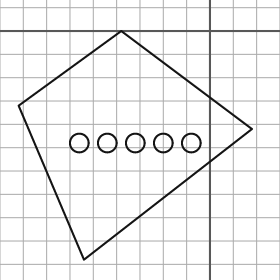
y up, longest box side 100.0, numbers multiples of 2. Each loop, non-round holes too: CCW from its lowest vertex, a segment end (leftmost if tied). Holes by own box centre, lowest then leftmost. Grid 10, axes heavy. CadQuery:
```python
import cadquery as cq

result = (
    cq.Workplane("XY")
    .moveTo(-54.0, -98.0)
    .lineTo(18.0, -42.0)
    .lineTo(-38.0, 0.0)
    .lineTo(-82.0, -32.0)
    .close()
    .moveTo(-56.0, -48.0)
    .circle(4.0)
    .moveTo(-44.0, -48.0)
    .circle(4.0)
    .moveTo(-32.0, -48.0)
    .circle(4.0)
    .moveTo(-20.0, -48.0)
    .circle(4.0)
    .moveTo(-8.0, -48.0)
    .circle(4.0)
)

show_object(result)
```